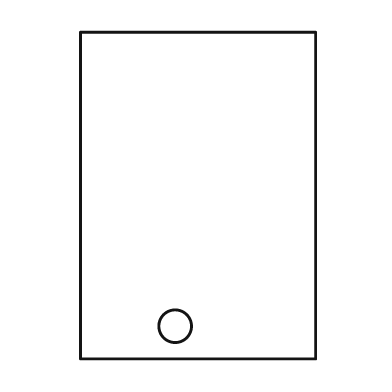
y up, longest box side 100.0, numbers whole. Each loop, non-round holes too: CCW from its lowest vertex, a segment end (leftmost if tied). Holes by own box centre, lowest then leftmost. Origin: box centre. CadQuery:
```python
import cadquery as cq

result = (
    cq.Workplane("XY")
    .moveTo(-36.0, -50.0)
    .lineTo(36.0, -50.0)
    .lineTo(36.0, 50.0)
    .lineTo(-36.0, 50.0)
    .close()
    .moveTo(-7.0, -40.0)
    .circle(5.0)
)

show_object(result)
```